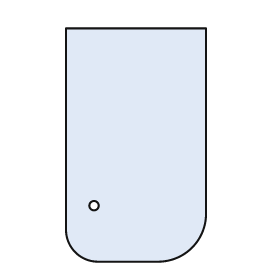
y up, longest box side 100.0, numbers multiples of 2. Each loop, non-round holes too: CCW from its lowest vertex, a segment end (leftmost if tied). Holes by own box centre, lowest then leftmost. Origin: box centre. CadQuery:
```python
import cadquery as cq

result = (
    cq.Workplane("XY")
    .moveTo(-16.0, -50.0)
    .lineTo(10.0, -50.0)
    .threePointArc((24.0, -44.0), (30.0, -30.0))
    .lineTo(30.0, 50.0)
    .lineTo(-30.0, 50.0)
    .lineTo(-30.0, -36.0)
    .threePointArc((-26.0, -46.0), (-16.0, -50.0))
    .close()
    .moveTo(-18.0, -26.0)
    .circle(2.0)
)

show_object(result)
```